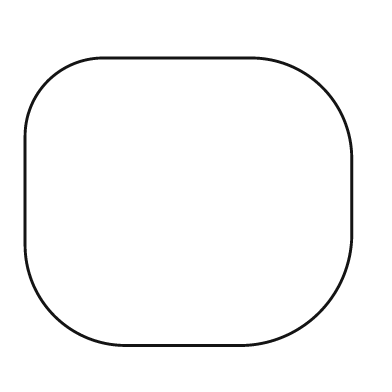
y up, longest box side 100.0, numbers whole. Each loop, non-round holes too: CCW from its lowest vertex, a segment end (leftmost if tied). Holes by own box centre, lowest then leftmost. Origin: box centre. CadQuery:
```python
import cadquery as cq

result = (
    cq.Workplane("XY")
    .moveTo(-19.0, -44.0)
    .lineTo(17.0, -44.0)
    .threePointArc((40.0, -34.0), (50.0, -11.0))
    .lineTo(50.0, 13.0)
    .threePointArc((41.0, 35.0), (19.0, 44.0))
    .lineTo(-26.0, 44.0)
    .threePointArc((-43.0, 37.0), (-50.0, 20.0))
    .lineTo(-50.0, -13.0)
    .threePointArc((-41.0, -35.0), (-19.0, -44.0))
    .close()
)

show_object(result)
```